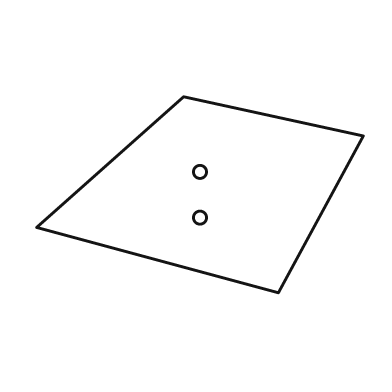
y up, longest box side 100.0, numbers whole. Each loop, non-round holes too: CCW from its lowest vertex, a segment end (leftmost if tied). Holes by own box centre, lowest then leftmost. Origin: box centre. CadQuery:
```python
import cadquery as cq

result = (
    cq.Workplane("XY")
    .moveTo(24.0, -30.0)
    .lineTo(50.0, 18.0)
    .lineTo(-5.0, 30.0)
    .lineTo(-50.0, -10.0)
    .close()
    .moveTo(0.0, -7.0)
    .circle(2.0)
    .moveTo(0.0, 7.0)
    .circle(2.0)
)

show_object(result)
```